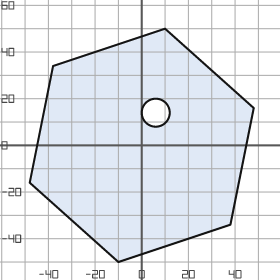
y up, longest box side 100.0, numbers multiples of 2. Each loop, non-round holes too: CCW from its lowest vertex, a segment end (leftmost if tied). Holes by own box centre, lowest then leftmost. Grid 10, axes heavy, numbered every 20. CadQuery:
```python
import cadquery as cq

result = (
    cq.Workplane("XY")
    .moveTo(-10.0, -50.0)
    .lineTo(38.0, -34.0)
    .lineTo(48.0, 16.0)
    .lineTo(10.0, 50.0)
    .lineTo(-38.0, 34.0)
    .lineTo(-48.0, -16.0)
    .close()
    .moveTo(6.0, 14.0)
    .circle(6.0)
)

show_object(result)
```